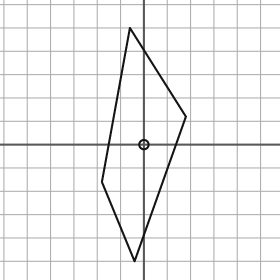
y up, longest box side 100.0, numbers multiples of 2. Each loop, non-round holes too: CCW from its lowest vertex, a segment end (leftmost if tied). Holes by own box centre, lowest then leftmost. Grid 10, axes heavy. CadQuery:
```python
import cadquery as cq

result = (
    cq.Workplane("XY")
    .moveTo(-4.0, -50.0)
    .lineTo(18.0, 12.0)
    .lineTo(-6.0, 50.0)
    .lineTo(-18.0, -16.0)
    .close()
    .moveTo(0.0, 0.0)
    .circle(2.0)
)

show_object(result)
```